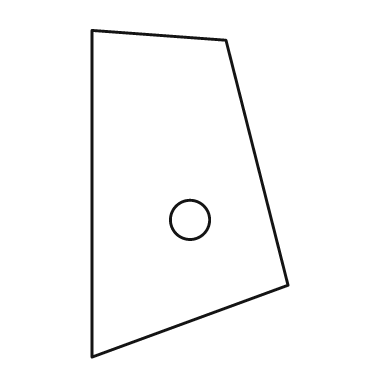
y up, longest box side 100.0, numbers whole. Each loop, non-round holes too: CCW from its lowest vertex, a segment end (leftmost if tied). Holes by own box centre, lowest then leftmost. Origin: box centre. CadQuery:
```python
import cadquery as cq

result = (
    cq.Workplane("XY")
    .moveTo(-30.0, -50.0)
    .lineTo(30.0, -28.0)
    .lineTo(11.0, 47.0)
    .lineTo(-30.0, 50.0)
    .close()
    .moveTo(0.0, -8.0)
    .circle(6.0)
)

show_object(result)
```